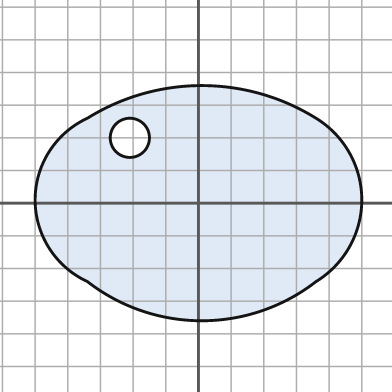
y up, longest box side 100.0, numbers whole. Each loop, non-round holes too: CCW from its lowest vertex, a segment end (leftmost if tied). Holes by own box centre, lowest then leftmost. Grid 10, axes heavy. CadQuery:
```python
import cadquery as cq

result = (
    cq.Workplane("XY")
    .moveTo(-34.0, -24.0)
    .threePointArc((1.0, -36.0), (36.0, -24.0))
    .threePointArc((50.0, 1.0), (36.0, 26.0))
    .threePointArc((1.0, 36.0), (-34.0, 26.0))
    .threePointArc((-50.0, 1.0), (-34.0, -24.0))
    .close()
    .moveTo(-21.0, 20.0)
    .circle(6.0)
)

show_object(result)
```